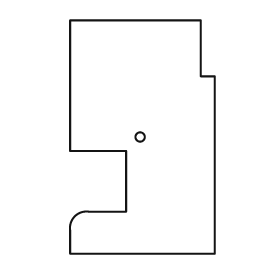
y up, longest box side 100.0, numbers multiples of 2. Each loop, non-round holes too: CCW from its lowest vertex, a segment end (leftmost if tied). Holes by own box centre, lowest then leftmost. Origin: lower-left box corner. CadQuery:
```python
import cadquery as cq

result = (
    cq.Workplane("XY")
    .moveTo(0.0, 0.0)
    .lineTo(62.0, 0.0)
    .lineTo(62.0, 76.0)
    .lineTo(56.0, 76.0)
    .lineTo(56.0, 100.0)
    .lineTo(0.0, 100.0)
    .lineTo(0.0, 44.0)
    .lineTo(24.0, 44.0)
    .lineTo(24.0, 18.0)
    .lineTo(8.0, 18.0)
    .threePointArc((2.0, 16.0), (0.0, 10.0))
    .close()
    .moveTo(30.0, 50.0)
    .circle(2.0)
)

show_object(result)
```